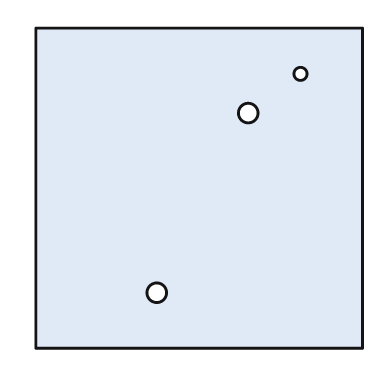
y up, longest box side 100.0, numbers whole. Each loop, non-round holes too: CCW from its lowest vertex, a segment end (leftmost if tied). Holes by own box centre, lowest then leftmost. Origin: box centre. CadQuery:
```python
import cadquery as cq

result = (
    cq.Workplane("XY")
    .moveTo(-50.0, -49.0)
    .lineTo(50.0, -49.0)
    .lineTo(50.0, 49.0)
    .lineTo(-50.0, 49.0)
    .close()
    .moveTo(-13.0, -32.0)
    .circle(3.0)
    .moveTo(15.0, 23.0)
    .circle(3.0)
    .moveTo(31.0, 35.0)
    .circle(2.0)
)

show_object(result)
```